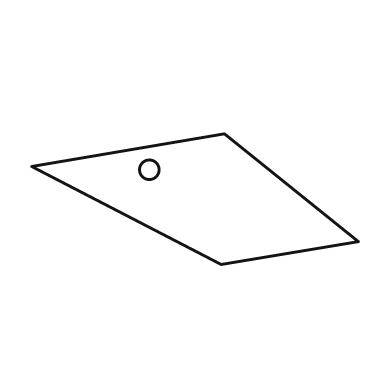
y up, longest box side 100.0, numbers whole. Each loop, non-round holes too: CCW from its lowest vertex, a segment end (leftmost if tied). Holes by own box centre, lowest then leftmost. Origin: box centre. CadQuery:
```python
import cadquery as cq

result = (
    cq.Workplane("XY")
    .moveTo(8.0, -20.0)
    .lineTo(50.0, -13.0)
    .lineTo(9.0, 20.0)
    .lineTo(-50.0, 10.0)
    .close()
    .moveTo(-14.0, 9.0)
    .circle(3.0)
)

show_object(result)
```